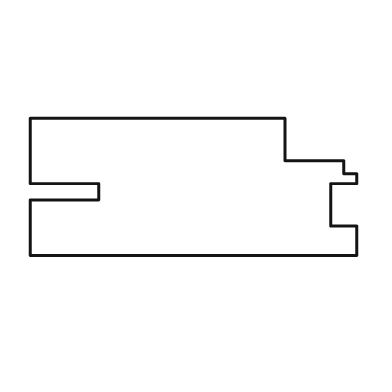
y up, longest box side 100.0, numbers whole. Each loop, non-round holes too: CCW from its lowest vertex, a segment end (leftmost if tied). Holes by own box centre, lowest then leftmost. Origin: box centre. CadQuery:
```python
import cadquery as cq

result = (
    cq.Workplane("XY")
    .moveTo(-50.0, -21.0)
    .lineTo(50.0, -21.0)
    .lineTo(50.0, -12.0)
    .lineTo(42.0, -12.0)
    .lineTo(42.0, 1.0)
    .lineTo(50.0, 1.0)
    .lineTo(50.0, 4.0)
    .lineTo(46.0, 4.0)
    .lineTo(46.0, 8.0)
    .lineTo(28.0, 8.0)
    .lineTo(28.0, 21.0)
    .lineTo(-50.0, 21.0)
    .lineTo(-50.0, 1.0)
    .lineTo(-29.0, 1.0)
    .lineTo(-29.0, -4.0)
    .lineTo(-50.0, -4.0)
    .close()
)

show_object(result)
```